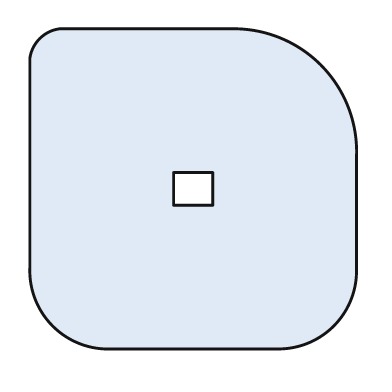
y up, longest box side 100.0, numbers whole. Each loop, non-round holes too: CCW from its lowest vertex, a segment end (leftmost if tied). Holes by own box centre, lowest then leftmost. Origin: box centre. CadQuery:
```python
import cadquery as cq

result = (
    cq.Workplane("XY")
    .moveTo(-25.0, -49.0)
    .lineTo(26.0, -49.0)
    .threePointArc((43.0, -42.0), (50.0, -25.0))
    .lineTo(50.0, 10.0)
    .threePointArc((39.0, 38.0), (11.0, 49.0))
    .lineTo(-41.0, 49.0)
    .threePointArc((-47.0, 46.0), (-50.0, 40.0))
    .lineTo(-50.0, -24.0)
    .threePointArc((-43.0, -42.0), (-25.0, -49.0))
    .close()
    .moveTo(-6.0, -5.0)
    .lineTo(6.0, -5.0)
    .lineTo(6.0, 5.0)
    .lineTo(-6.0, 5.0)
    .close()
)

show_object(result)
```